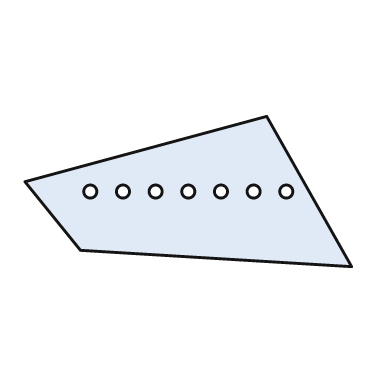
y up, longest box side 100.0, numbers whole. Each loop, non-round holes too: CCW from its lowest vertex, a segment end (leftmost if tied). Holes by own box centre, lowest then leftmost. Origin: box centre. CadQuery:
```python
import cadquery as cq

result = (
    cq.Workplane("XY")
    .moveTo(50.0, -23.0)
    .lineTo(24.0, 23.0)
    .lineTo(-50.0, 3.0)
    .lineTo(-33.0, -18.0)
    .close()
    .moveTo(-30.0, 0.0)
    .circle(2.0)
    .moveTo(-20.0, 0.0)
    .circle(2.0)
    .moveTo(-10.0, 0.0)
    .circle(2.0)
    .moveTo(0.0, 0.0)
    .circle(2.0)
    .moveTo(10.0, 0.0)
    .circle(2.0)
    .moveTo(20.0, 0.0)
    .circle(2.0)
    .moveTo(30.0, 0.0)
    .circle(2.0)
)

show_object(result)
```